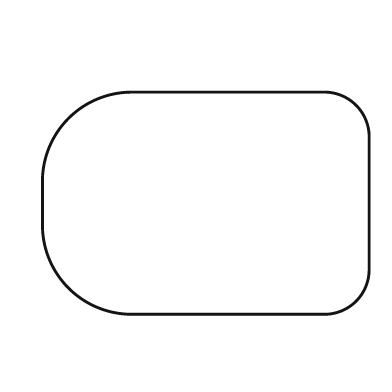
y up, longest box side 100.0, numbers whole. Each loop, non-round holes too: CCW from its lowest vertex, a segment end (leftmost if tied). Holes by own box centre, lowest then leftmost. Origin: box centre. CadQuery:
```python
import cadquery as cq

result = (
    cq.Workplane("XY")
    .moveTo(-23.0, -34.0)
    .lineTo(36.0, -34.0)
    .threePointArc((46.0, -30.0), (50.0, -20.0))
    .lineTo(50.0, 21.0)
    .threePointArc((46.0, 30.0), (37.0, 34.0))
    .lineTo(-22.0, 34.0)
    .threePointArc((-42.0, 26.0), (-50.0, 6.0))
    .lineTo(-50.0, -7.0)
    .threePointArc((-42.0, -26.0), (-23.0, -34.0))
    .close()
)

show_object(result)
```